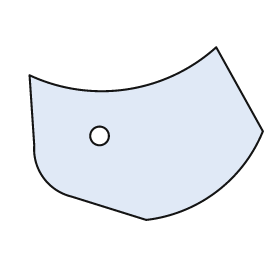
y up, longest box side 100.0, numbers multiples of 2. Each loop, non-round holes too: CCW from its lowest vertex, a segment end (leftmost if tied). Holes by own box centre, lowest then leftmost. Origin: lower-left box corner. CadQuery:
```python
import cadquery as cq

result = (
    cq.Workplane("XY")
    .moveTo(50.0, 0.0)
    .threePointArc((80.0, 12.0), (100.0, 38.0))
    .lineTo(80.0, 74.0)
    .threePointArc((42.0, 56.0), (0.0, 62.0))
    .lineTo(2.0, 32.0)
    .threePointArc((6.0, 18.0), (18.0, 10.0))
    .close()
    .moveTo(30.0, 36.0)
    .circle(4.0)
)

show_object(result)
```